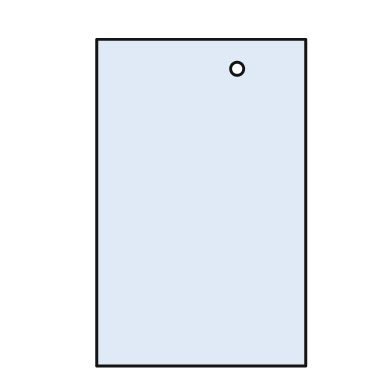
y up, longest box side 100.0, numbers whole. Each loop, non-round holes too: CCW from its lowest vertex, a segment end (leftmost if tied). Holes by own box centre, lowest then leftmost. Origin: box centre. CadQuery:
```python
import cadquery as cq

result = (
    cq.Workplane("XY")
    .moveTo(-32.0, -50.0)
    .lineTo(32.0, -50.0)
    .lineTo(32.0, 50.0)
    .lineTo(-32.0, 50.0)
    .close()
    .moveTo(11.0, 41.0)
    .circle(2.0)
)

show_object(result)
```